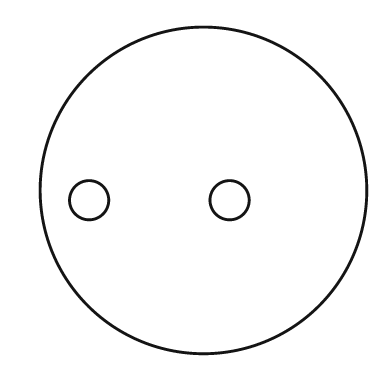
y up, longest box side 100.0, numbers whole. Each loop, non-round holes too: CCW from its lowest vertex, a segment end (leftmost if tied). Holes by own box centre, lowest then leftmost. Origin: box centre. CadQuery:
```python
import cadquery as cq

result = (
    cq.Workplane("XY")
    .moveTo(0.0, 0.0)
    .circle(50.0)
    .moveTo(-35.0, -3.0)
    .circle(6.0)
    .moveTo(8.0, -3.0)
    .circle(6.0)
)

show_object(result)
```